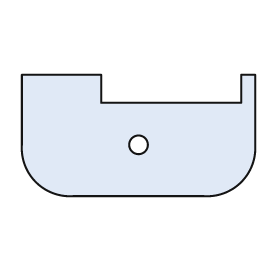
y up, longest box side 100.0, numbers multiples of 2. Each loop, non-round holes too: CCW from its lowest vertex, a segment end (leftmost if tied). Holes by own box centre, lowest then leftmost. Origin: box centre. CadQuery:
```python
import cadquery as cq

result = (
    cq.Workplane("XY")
    .moveTo(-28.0, -26.0)
    .lineTo(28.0, -26.0)
    .threePointArc((44.0, -20.0), (50.0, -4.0))
    .lineTo(50.0, 26.0)
    .lineTo(44.0, 26.0)
    .lineTo(44.0, 14.0)
    .lineTo(-16.0, 14.0)
    .lineTo(-16.0, 26.0)
    .lineTo(-50.0, 26.0)
    .lineTo(-50.0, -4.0)
    .threePointArc((-44.0, -20.0), (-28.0, -26.0))
    .close()
    .moveTo(0.0, -4.0)
    .circle(4.0)
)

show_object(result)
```